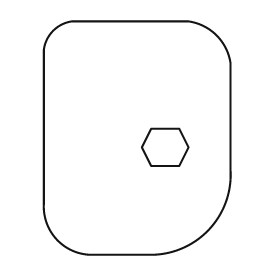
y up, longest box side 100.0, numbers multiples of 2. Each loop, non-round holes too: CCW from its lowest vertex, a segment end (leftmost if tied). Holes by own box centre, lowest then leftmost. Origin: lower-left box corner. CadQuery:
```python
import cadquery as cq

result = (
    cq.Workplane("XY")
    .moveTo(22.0, 0.0)
    .lineTo(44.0, 0.0)
    .threePointArc((70.0, 10.0), (80.0, 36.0))
    .lineTo(80.0, 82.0)
    .threePointArc((74.0, 94.0), (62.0, 100.0))
    .lineTo(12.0, 100.0)
    .threePointArc((4.0, 96.0), (0.0, 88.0))
    .lineTo(0.0, 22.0)
    .threePointArc((6.0, 6.0), (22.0, 0.0))
    .close()
    .moveTo(46.0, 38.0)
    .lineTo(58.0, 38.0)
    .lineTo(62.0, 46.0)
    .lineTo(58.0, 54.0)
    .lineTo(46.0, 54.0)
    .lineTo(42.0, 46.0)
    .close()
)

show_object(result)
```